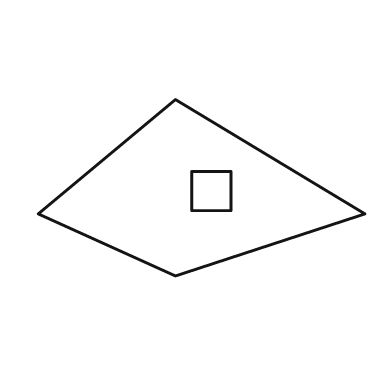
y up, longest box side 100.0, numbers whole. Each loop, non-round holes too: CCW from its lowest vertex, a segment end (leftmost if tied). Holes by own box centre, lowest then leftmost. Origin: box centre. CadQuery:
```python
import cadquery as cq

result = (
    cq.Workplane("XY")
    .moveTo(-8.0, -27.0)
    .lineTo(50.0, -8.0)
    .lineTo(-8.0, 27.0)
    .lineTo(-50.0, -8.0)
    .close()
    .moveTo(-3.0, -7.0)
    .lineTo(9.0, -7.0)
    .lineTo(9.0, 5.0)
    .lineTo(-3.0, 5.0)
    .close()
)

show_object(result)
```